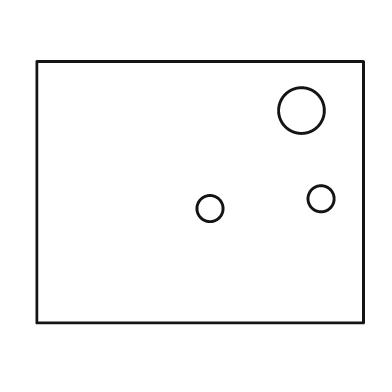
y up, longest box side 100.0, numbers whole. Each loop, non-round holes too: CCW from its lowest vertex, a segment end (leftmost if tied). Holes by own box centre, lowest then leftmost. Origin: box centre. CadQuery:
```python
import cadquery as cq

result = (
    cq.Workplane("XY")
    .moveTo(-50.0, -40.0)
    .lineTo(50.0, -40.0)
    .lineTo(50.0, 40.0)
    .lineTo(-50.0, 40.0)
    .close()
    .moveTo(3.0, -5.0)
    .circle(4.0)
    .moveTo(37.0, -2.0)
    .circle(4.0)
    .moveTo(31.0, 25.0)
    .circle(7.0)
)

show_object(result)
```